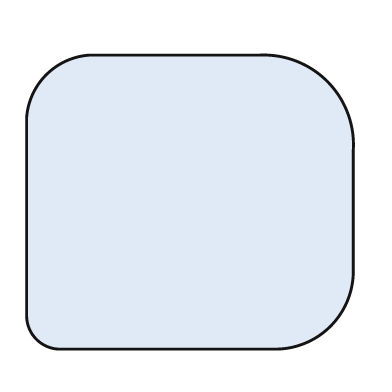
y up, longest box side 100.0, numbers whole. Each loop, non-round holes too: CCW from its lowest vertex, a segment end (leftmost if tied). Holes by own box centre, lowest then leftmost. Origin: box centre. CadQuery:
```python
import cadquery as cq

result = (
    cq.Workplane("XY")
    .moveTo(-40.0, -45.0)
    .lineTo(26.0, -45.0)
    .threePointArc((43.0, -38.0), (50.0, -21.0))
    .lineTo(50.0, 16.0)
    .threePointArc((42.0, 37.0), (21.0, 45.0))
    .lineTo(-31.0, 45.0)
    .threePointArc((-44.0, 39.0), (-50.0, 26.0))
    .lineTo(-50.0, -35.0)
    .threePointArc((-47.0, -42.0), (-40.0, -45.0))
    .close()
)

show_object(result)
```